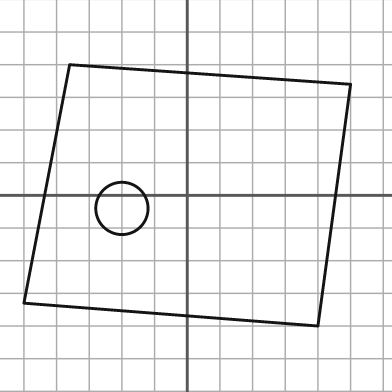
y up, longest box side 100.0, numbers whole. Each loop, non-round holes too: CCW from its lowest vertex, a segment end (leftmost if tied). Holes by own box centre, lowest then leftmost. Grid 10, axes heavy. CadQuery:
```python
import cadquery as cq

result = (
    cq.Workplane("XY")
    .moveTo(40.0, -40.0)
    .lineTo(50.0, 34.0)
    .lineTo(-36.0, 40.0)
    .lineTo(-50.0, -33.0)
    .close()
    .moveTo(-20.0, -4.0)
    .circle(8.0)
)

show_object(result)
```